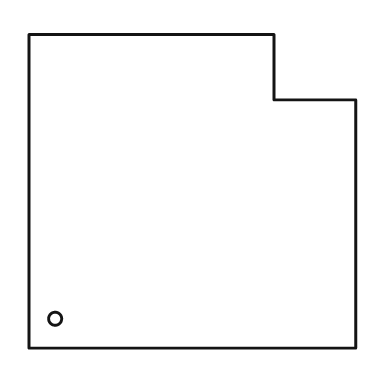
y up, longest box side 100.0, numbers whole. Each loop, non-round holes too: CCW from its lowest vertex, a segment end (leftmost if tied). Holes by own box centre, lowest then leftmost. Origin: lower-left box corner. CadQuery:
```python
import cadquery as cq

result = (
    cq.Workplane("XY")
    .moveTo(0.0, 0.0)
    .lineTo(100.0, 0.0)
    .lineTo(100.0, 76.0)
    .lineTo(75.0, 76.0)
    .lineTo(75.0, 96.0)
    .lineTo(0.0, 96.0)
    .close()
    .moveTo(8.0, 9.0)
    .circle(2.0)
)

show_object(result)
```